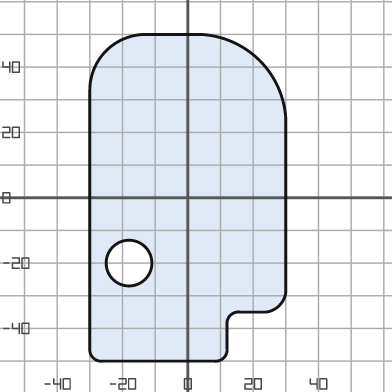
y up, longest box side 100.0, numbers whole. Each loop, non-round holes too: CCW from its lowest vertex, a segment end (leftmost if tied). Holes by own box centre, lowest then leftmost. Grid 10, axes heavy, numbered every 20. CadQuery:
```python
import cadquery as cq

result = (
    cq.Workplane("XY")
    .moveTo(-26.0, -50.0)
    .lineTo(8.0, -50.0)
    .threePointArc((11.0, -49.0), (12.0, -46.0))
    .lineTo(12.0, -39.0)
    .threePointArc((13.0, -36.0), (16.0, -35.0))
    .lineTo(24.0, -35.0)
    .threePointArc((28.0, -33.0), (30.0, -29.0))
    .lineTo(30.0, 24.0)
    .threePointArc((22.0, 42.0), (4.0, 50.0))
    .lineTo(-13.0, 50.0)
    .threePointArc((-25.0, 45.0), (-30.0, 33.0))
    .lineTo(-30.0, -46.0)
    .threePointArc((-29.0, -49.0), (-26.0, -50.0))
    .close()
    .moveTo(-18.0, -20.0)
    .circle(7.0)
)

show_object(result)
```